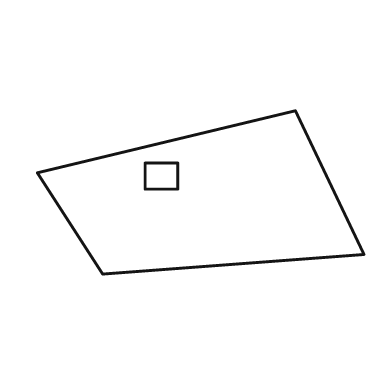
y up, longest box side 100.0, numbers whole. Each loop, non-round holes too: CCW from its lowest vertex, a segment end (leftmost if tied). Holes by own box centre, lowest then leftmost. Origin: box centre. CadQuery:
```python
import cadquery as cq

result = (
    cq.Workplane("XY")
    .moveTo(-30.0, -25.0)
    .lineTo(50.0, -19.0)
    .lineTo(29.0, 25.0)
    .lineTo(-50.0, 6.0)
    .close()
    .moveTo(-17.0, 1.0)
    .lineTo(-7.0, 1.0)
    .lineTo(-7.0, 9.0)
    .lineTo(-17.0, 9.0)
    .close()
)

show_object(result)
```